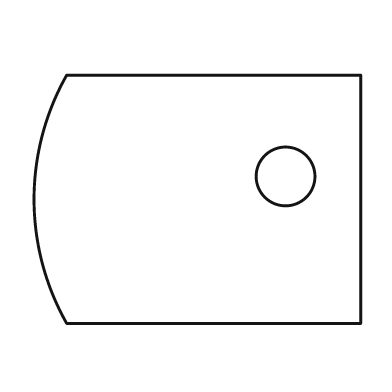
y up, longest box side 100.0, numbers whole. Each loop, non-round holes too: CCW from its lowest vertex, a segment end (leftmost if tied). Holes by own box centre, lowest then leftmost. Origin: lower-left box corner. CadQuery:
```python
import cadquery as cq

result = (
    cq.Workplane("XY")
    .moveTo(10.0, 0.0)
    .lineTo(100.0, 0.0)
    .lineTo(100.0, 76.0)
    .lineTo(10.0, 76.0)
    .threePointArc((0.0, 38.0), (10.0, 0.0))
    .close()
    .moveTo(77.0, 45.0)
    .circle(9.0)
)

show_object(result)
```